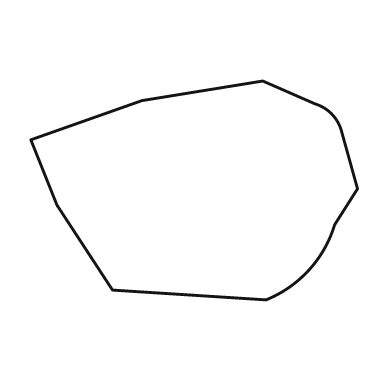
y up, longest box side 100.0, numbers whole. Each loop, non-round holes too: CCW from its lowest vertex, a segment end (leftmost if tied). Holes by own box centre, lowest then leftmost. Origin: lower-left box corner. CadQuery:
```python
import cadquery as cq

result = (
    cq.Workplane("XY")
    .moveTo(72.0, 0.0)
    .threePointArc((85.0, 9.0), (93.0, 23.0))
    .lineTo(100.0, 34.0)
    .lineTo(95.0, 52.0)
    .threePointArc((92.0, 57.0), (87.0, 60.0))
    .lineTo(71.0, 67.0)
    .lineTo(34.0, 61.0)
    .lineTo(0.0, 49.0)
    .lineTo(8.0, 29.0)
    .lineTo(25.0, 3.0)
    .close()
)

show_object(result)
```